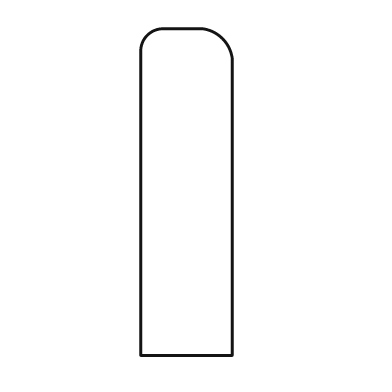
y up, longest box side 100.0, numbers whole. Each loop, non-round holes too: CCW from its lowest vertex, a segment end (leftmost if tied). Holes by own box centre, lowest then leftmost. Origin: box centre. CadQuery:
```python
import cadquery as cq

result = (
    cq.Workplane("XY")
    .moveTo(-14.0, -50.0)
    .lineTo(14.0, -50.0)
    .lineTo(14.0, 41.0)
    .threePointArc((11.0, 47.0), (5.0, 50.0))
    .lineTo(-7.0, 50.0)
    .threePointArc((-12.0, 48.0), (-14.0, 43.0))
    .close()
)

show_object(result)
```